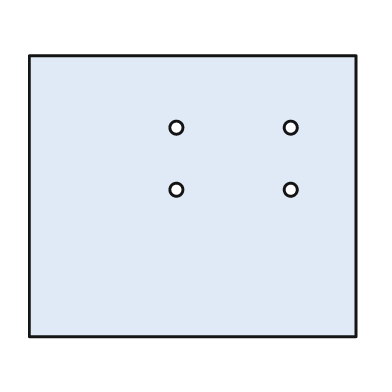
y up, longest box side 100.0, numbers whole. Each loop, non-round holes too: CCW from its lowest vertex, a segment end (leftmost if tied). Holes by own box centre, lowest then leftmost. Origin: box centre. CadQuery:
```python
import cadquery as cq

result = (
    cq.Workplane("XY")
    .moveTo(-50.0, -43.0)
    .lineTo(50.0, -43.0)
    .lineTo(50.0, 43.0)
    .lineTo(-50.0, 43.0)
    .close()
    .moveTo(-5.0, 2.0)
    .circle(2.0)
    .moveTo(30.0, 2.0)
    .circle(2.0)
    .moveTo(-5.0, 21.0)
    .circle(2.0)
    .moveTo(30.0, 21.0)
    .circle(2.0)
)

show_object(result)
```